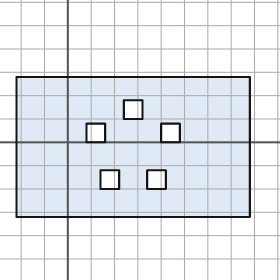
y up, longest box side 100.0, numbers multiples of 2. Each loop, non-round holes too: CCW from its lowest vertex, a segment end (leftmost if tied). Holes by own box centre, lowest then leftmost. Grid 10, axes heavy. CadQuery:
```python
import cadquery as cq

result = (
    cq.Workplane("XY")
    .moveTo(-22.0, -32.0)
    .lineTo(78.0, -32.0)
    .lineTo(78.0, 28.0)
    .lineTo(-22.0, 28.0)
    .close()
    .moveTo(14.0, -20.0)
    .lineTo(22.0, -20.0)
    .lineTo(22.0, -12.0)
    .lineTo(14.0, -12.0)
    .close()
    .moveTo(34.0, -20.0)
    .lineTo(42.0, -20.0)
    .lineTo(42.0, -12.0)
    .lineTo(34.0, -12.0)
    .close()
    .moveTo(8.0, 0.0)
    .lineTo(16.0, 0.0)
    .lineTo(16.0, 8.0)
    .lineTo(8.0, 8.0)
    .close()
    .moveTo(40.0, 0.0)
    .lineTo(48.0, 0.0)
    .lineTo(48.0, 8.0)
    .lineTo(40.0, 8.0)
    .close()
    .moveTo(24.0, 10.0)
    .lineTo(32.0, 10.0)
    .lineTo(32.0, 18.0)
    .lineTo(24.0, 18.0)
    .close()
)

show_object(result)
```